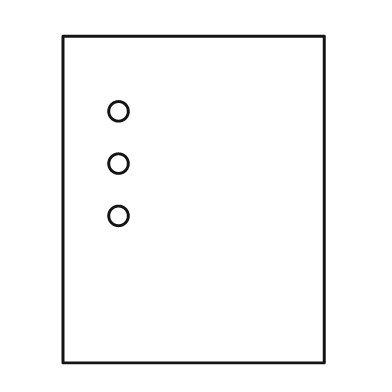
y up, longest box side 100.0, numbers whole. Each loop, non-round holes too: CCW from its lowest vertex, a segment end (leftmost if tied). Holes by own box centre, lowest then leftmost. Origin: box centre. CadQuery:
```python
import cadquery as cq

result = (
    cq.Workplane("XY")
    .moveTo(-40.0, -50.0)
    .lineTo(40.0, -50.0)
    .lineTo(40.0, 50.0)
    .lineTo(-40.0, 50.0)
    .close()
    .moveTo(-23.0, -5.0)
    .circle(3.0)
    .moveTo(-23.0, 11.0)
    .circle(3.0)
    .moveTo(-23.0, 27.0)
    .circle(3.0)
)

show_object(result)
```